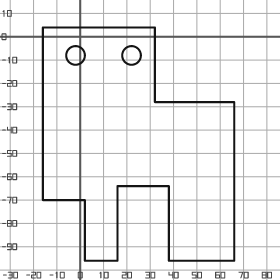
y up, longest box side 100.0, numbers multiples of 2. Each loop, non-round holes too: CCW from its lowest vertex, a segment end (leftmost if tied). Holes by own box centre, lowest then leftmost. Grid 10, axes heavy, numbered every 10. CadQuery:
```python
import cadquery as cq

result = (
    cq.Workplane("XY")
    .moveTo(2.0, -96.0)
    .lineTo(16.0, -96.0)
    .lineTo(16.0, -64.0)
    .lineTo(38.0, -64.0)
    .lineTo(38.0, -96.0)
    .lineTo(66.0, -96.0)
    .lineTo(66.0, -28.0)
    .lineTo(32.0, -28.0)
    .lineTo(32.0, 4.0)
    .lineTo(-16.0, 4.0)
    .lineTo(-16.0, -70.0)
    .lineTo(2.0, -70.0)
    .close()
    .moveTo(-2.0, -8.0)
    .circle(4.0)
    .moveTo(22.0, -8.0)
    .circle(4.0)
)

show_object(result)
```